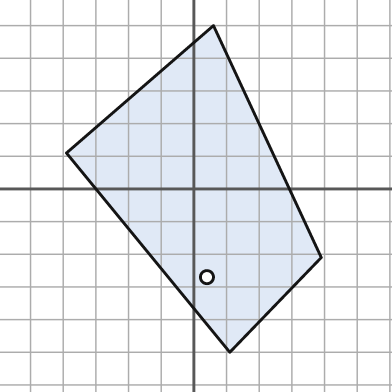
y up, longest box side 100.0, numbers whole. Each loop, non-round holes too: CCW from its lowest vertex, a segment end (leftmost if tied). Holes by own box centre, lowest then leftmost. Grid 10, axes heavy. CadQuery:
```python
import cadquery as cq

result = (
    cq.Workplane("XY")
    .moveTo(11.0, -50.0)
    .lineTo(39.0, -21.0)
    .lineTo(6.0, 50.0)
    .lineTo(-39.0, 11.0)
    .close()
    .moveTo(4.0, -27.0)
    .circle(2.0)
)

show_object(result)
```